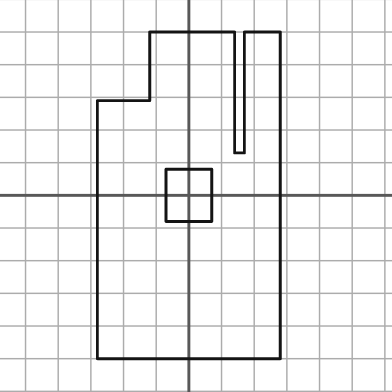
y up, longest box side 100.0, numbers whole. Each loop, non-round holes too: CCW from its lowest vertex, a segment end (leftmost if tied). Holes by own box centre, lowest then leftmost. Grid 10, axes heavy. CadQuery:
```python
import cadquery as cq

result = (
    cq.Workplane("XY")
    .moveTo(-28.0, -50.0)
    .lineTo(28.0, -50.0)
    .lineTo(28.0, 50.0)
    .lineTo(17.0, 50.0)
    .lineTo(17.0, 13.0)
    .lineTo(14.0, 13.0)
    .lineTo(14.0, 50.0)
    .lineTo(-12.0, 50.0)
    .lineTo(-12.0, 29.0)
    .lineTo(-28.0, 29.0)
    .close()
    .moveTo(-7.0, -8.0)
    .lineTo(7.0, -8.0)
    .lineTo(7.0, 8.0)
    .lineTo(-7.0, 8.0)
    .close()
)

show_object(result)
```